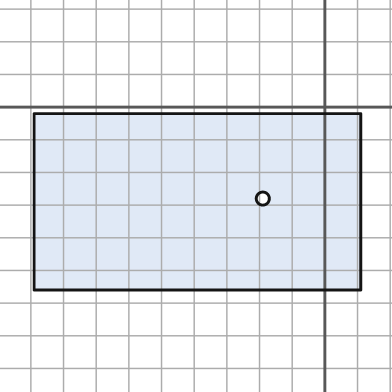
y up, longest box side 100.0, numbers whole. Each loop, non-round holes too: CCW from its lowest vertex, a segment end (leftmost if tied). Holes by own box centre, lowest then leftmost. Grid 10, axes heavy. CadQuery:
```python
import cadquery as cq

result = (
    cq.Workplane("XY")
    .moveTo(-89.0, -56.0)
    .lineTo(11.0, -56.0)
    .lineTo(11.0, -2.0)
    .lineTo(-89.0, -2.0)
    .close()
    .moveTo(-19.0, -28.0)
    .circle(2.0)
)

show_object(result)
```